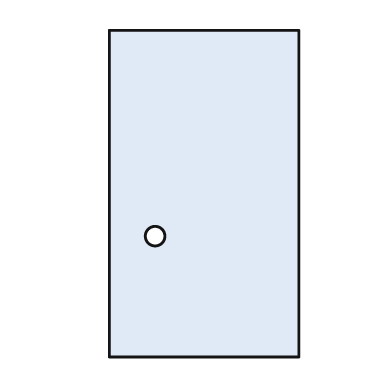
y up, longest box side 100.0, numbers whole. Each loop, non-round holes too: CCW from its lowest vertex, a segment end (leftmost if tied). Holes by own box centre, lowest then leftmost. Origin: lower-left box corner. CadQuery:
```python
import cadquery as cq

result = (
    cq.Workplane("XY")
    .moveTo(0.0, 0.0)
    .lineTo(58.0, 0.0)
    .lineTo(58.0, 100.0)
    .lineTo(0.0, 100.0)
    .close()
    .moveTo(14.0, 37.0)
    .circle(3.0)
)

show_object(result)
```